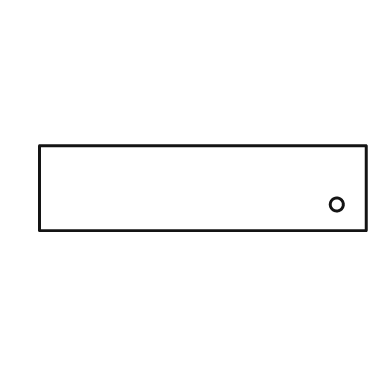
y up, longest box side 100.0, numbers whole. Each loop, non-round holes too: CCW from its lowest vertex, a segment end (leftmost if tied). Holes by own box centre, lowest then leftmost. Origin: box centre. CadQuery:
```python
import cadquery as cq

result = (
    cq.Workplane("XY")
    .moveTo(-50.0, -13.0)
    .lineTo(50.0, -13.0)
    .lineTo(50.0, 13.0)
    .lineTo(-50.0, 13.0)
    .close()
    .moveTo(41.0, -5.0)
    .circle(2.0)
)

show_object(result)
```